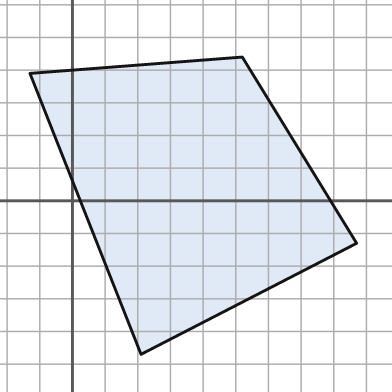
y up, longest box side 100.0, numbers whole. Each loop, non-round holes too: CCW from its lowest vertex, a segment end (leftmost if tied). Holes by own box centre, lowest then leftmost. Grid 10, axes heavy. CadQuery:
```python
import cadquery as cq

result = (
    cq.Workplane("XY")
    .moveTo(21.0, -47.0)
    .lineTo(87.0, -13.0)
    .lineTo(52.0, 44.0)
    .lineTo(-13.0, 39.0)
    .close()
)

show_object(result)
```